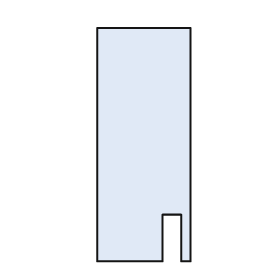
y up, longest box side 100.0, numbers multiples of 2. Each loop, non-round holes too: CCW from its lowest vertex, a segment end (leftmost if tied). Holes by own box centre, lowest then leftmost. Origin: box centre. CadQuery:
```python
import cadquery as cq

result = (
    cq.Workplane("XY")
    .moveTo(-20.0, -50.0)
    .lineTo(8.0, -50.0)
    .lineTo(8.0, -30.0)
    .lineTo(16.0, -30.0)
    .lineTo(16.0, -50.0)
    .lineTo(20.0, -50.0)
    .lineTo(20.0, 50.0)
    .lineTo(-20.0, 50.0)
    .close()
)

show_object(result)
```